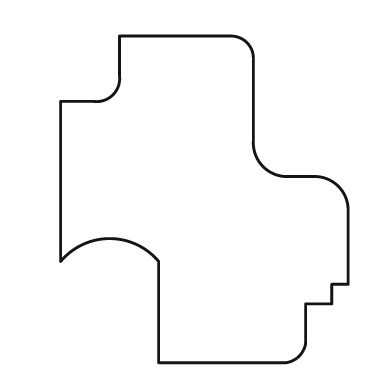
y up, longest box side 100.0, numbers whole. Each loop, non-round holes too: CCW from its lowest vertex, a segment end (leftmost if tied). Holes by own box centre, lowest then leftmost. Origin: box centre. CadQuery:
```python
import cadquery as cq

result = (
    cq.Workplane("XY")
    .moveTo(-14.0, -50.0)
    .lineTo(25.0, -50.0)
    .threePointArc((29.0, -48.0), (31.0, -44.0))
    .lineTo(31.0, -32.0)
    .lineTo(39.0, -32.0)
    .lineTo(39.0, -26.0)
    .lineTo(44.0, -26.0)
    .lineTo(44.0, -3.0)
    .threePointArc((41.0, 4.0), (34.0, 7.0))
    .lineTo(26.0, 7.0)
    .threePointArc((18.0, 10.0), (15.0, 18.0))
    .lineTo(15.0, 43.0)
    .threePointArc((13.0, 48.0), (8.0, 50.0))
    .lineTo(-26.0, 50.0)
    .lineTo(-26.0, 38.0)
    .threePointArc((-28.0, 32.0), (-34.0, 30.0))
    .lineTo(-44.0, 30.0)
    .lineTo(-44.0, -19.0)
    .threePointArc((-29.0, -12.0), (-14.0, -19.0))
    .close()
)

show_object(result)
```